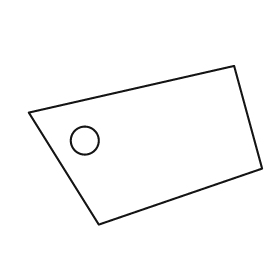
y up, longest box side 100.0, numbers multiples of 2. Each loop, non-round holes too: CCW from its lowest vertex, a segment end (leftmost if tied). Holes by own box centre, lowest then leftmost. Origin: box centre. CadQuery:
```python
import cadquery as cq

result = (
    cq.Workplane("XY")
    .moveTo(-20.0, -34.0)
    .lineTo(50.0, -10.0)
    .lineTo(38.0, 34.0)
    .lineTo(-50.0, 14.0)
    .close()
    .moveTo(-26.0, 2.0)
    .circle(6.0)
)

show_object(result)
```